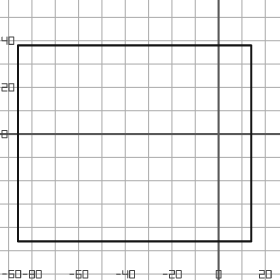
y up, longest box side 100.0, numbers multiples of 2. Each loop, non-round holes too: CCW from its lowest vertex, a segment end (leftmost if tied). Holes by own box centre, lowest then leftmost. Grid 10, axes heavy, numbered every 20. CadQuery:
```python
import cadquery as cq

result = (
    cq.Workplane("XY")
    .moveTo(-86.0, -46.0)
    .lineTo(14.0, -46.0)
    .lineTo(14.0, 38.0)
    .lineTo(-86.0, 38.0)
    .close()
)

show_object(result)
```